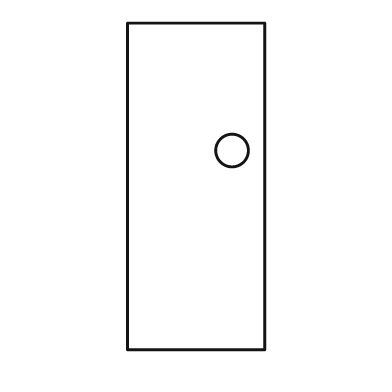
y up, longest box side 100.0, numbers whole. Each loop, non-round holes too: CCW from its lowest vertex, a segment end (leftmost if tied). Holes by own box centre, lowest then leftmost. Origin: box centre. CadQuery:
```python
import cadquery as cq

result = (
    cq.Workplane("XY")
    .moveTo(-21.0, -50.0)
    .lineTo(21.0, -50.0)
    .lineTo(21.0, 50.0)
    .lineTo(-21.0, 50.0)
    .close()
    .moveTo(11.0, 11.0)
    .circle(5.0)
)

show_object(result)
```